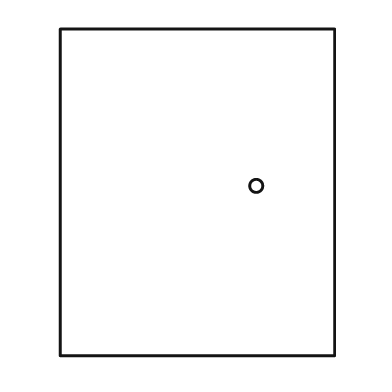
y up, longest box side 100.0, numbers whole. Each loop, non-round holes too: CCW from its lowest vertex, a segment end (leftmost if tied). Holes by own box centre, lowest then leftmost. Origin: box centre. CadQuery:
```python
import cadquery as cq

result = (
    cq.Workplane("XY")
    .moveTo(-42.0, -50.0)
    .lineTo(42.0, -50.0)
    .lineTo(42.0, 50.0)
    .lineTo(-42.0, 50.0)
    .close()
    .moveTo(18.0, 2.0)
    .circle(2.0)
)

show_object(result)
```